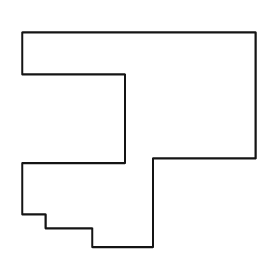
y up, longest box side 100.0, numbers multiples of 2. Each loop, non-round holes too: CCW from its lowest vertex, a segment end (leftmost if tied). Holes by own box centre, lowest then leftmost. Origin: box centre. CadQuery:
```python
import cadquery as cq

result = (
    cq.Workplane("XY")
    .moveTo(-20.0, -46.0)
    .lineTo(6.0, -46.0)
    .lineTo(6.0, -8.0)
    .lineTo(50.0, -8.0)
    .lineTo(50.0, 46.0)
    .lineTo(-50.0, 46.0)
    .lineTo(-50.0, 28.0)
    .lineTo(-6.0, 28.0)
    .lineTo(-6.0, -10.0)
    .lineTo(-50.0, -10.0)
    .lineTo(-50.0, -32.0)
    .lineTo(-40.0, -32.0)
    .lineTo(-40.0, -38.0)
    .lineTo(-20.0, -38.0)
    .close()
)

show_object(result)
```